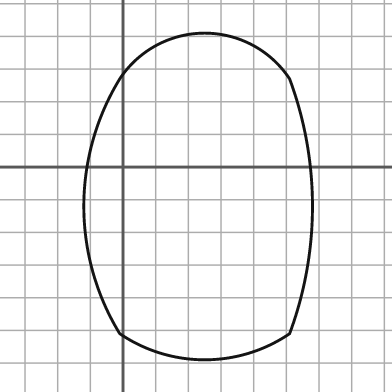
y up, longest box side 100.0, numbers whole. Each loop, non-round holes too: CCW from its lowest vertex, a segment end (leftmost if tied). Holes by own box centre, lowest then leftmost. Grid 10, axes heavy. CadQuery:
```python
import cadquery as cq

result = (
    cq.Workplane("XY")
    .moveTo(-1.0, -51.0)
    .threePointArc((25.0, -59.0), (51.0, -51.0))
    .threePointArc((58.0, -12.0), (51.0, 27.0))
    .threePointArc((25.0, 41.0), (-1.0, 27.0))
    .threePointArc((-12.0, -12.0), (-1.0, -51.0))
    .close()
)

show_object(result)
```